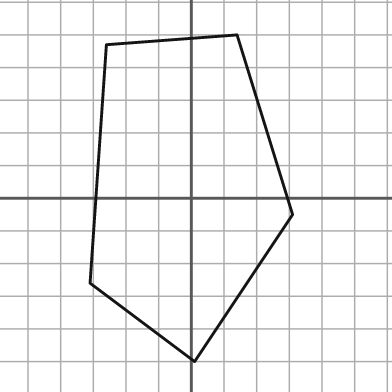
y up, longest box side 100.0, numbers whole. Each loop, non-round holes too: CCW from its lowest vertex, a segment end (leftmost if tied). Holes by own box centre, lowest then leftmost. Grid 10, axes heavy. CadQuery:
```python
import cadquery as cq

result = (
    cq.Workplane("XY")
    .moveTo(1.0, -50.0)
    .lineTo(31.0, -5.0)
    .lineTo(14.0, 50.0)
    .lineTo(-26.0, 47.0)
    .lineTo(-31.0, -26.0)
    .close()
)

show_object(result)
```